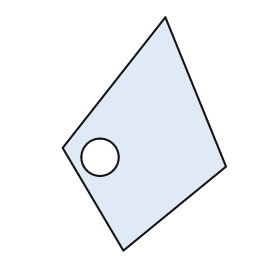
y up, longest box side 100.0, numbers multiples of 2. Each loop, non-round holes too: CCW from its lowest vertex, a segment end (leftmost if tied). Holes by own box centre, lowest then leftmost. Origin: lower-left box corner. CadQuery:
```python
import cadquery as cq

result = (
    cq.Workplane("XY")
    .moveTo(26.0, 0.0)
    .lineTo(70.0, 36.0)
    .lineTo(44.0, 100.0)
    .lineTo(0.0, 44.0)
    .close()
    .moveTo(16.0, 40.0)
    .circle(8.0)
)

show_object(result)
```